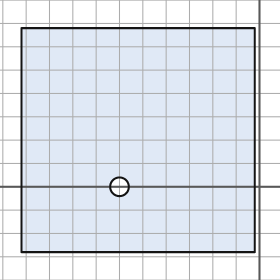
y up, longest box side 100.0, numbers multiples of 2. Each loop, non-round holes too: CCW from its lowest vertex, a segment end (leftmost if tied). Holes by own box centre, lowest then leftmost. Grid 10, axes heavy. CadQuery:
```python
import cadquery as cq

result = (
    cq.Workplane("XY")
    .moveTo(-102.0, -28.0)
    .lineTo(-2.0, -28.0)
    .lineTo(-2.0, 68.0)
    .lineTo(-102.0, 68.0)
    .close()
    .moveTo(-60.0, 0.0)
    .circle(4.0)
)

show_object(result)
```